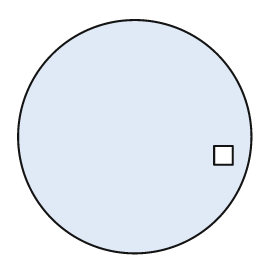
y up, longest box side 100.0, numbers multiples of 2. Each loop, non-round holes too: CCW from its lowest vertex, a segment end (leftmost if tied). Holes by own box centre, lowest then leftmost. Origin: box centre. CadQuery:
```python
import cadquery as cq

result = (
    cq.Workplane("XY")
    .moveTo(0.0, 0.0)
    .circle(50.0)
    .moveTo(34.0, -12.0)
    .lineTo(42.0, -12.0)
    .lineTo(42.0, -4.0)
    .lineTo(34.0, -4.0)
    .close()
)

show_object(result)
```